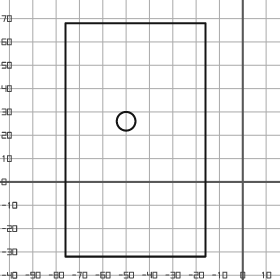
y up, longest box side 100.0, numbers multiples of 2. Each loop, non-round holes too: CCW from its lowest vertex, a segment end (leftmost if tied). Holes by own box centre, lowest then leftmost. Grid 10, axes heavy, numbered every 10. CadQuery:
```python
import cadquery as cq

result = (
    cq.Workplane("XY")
    .moveTo(-76.0, -32.0)
    .lineTo(-16.0, -32.0)
    .lineTo(-16.0, 68.0)
    .lineTo(-76.0, 68.0)
    .close()
    .moveTo(-50.0, 26.0)
    .circle(4.0)
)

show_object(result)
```